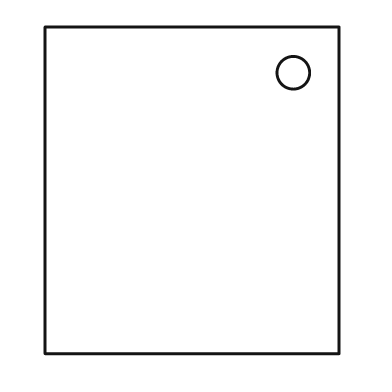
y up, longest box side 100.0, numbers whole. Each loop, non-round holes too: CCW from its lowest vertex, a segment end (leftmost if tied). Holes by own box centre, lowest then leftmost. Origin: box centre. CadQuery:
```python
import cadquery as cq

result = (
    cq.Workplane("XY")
    .moveTo(-45.0, -50.0)
    .lineTo(45.0, -50.0)
    .lineTo(45.0, 50.0)
    .lineTo(-45.0, 50.0)
    .close()
    .moveTo(31.0, 36.0)
    .circle(5.0)
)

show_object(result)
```